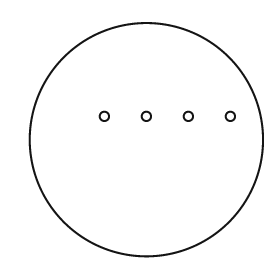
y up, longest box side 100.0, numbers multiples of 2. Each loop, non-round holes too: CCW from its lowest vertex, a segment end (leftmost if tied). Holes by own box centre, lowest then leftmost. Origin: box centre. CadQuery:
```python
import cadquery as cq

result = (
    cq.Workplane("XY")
    .moveTo(0.0, 0.0)
    .circle(50.0)
    .moveTo(-18.0, 10.0)
    .circle(2.0)
    .moveTo(0.0, 10.0)
    .circle(2.0)
    .moveTo(18.0, 10.0)
    .circle(2.0)
    .moveTo(36.0, 10.0)
    .circle(2.0)
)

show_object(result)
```